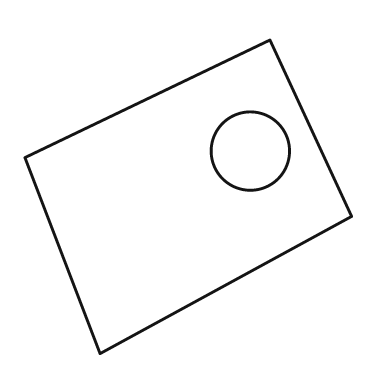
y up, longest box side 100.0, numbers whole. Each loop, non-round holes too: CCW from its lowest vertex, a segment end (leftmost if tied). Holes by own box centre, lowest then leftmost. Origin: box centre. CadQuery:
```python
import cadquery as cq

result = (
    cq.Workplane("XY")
    .moveTo(-27.0, -48.0)
    .lineTo(50.0, -6.0)
    .lineTo(25.0, 48.0)
    .lineTo(-50.0, 12.0)
    .close()
    .moveTo(19.0, 14.0)
    .circle(12.0)
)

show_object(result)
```